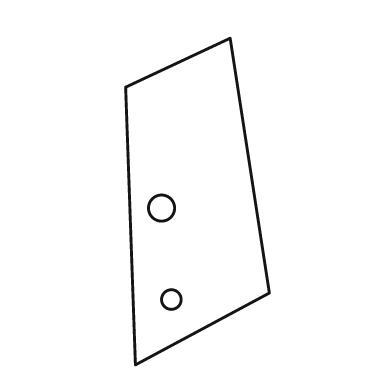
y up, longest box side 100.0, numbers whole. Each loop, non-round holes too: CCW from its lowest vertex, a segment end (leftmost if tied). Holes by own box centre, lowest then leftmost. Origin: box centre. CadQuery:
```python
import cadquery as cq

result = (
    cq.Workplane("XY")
    .moveTo(-19.0, -50.0)
    .lineTo(22.0, -28.0)
    .lineTo(10.0, 50.0)
    .lineTo(-22.0, 35.0)
    .close()
    .moveTo(-8.0, -30.0)
    .circle(3.0)
    .moveTo(-11.0, -2.0)
    .circle(4.0)
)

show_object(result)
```